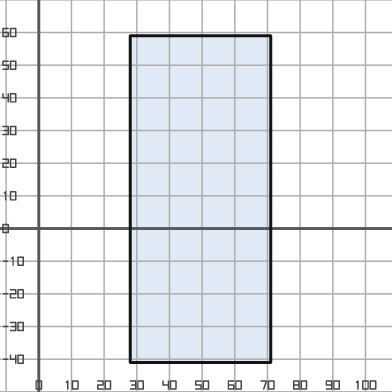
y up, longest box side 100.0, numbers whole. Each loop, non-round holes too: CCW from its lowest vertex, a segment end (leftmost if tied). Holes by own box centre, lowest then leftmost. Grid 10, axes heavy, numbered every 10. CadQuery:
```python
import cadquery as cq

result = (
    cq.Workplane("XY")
    .moveTo(28.0, -41.0)
    .lineTo(71.0, -41.0)
    .lineTo(71.0, 59.0)
    .lineTo(28.0, 59.0)
    .close()
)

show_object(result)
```